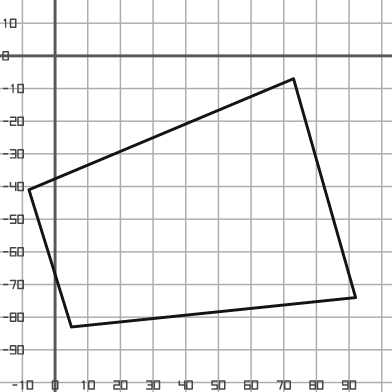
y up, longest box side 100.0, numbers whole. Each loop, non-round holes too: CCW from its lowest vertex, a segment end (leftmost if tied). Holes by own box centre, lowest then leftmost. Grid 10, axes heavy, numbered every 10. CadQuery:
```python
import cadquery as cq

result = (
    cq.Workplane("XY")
    .moveTo(5.0, -83.0)
    .lineTo(92.0, -74.0)
    .lineTo(73.0, -7.0)
    .lineTo(-8.0, -41.0)
    .close()
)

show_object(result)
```